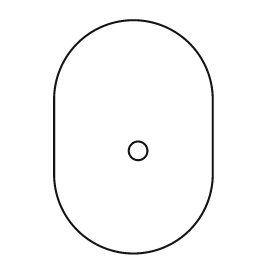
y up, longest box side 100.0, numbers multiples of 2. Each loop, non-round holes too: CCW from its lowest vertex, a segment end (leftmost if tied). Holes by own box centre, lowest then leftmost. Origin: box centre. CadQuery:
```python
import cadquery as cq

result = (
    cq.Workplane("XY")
    .moveTo(-34.0, -16.0)
    .threePointArc((0.0, -50.0), (34.0, -16.0))
    .lineTo(34.0, 16.0)
    .threePointArc((0.0, 50.0), (-34.0, 16.0))
    .close()
    .moveTo(2.0, -6.0)
    .circle(4.0)
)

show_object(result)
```